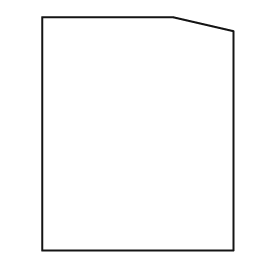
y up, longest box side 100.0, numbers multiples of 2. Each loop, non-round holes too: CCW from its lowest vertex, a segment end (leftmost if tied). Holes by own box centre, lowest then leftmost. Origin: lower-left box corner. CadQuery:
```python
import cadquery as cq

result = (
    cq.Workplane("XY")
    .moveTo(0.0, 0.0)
    .lineTo(82.0, 0.0)
    .lineTo(82.0, 94.0)
    .lineTo(56.0, 100.0)
    .lineTo(0.0, 100.0)
    .close()
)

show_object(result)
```